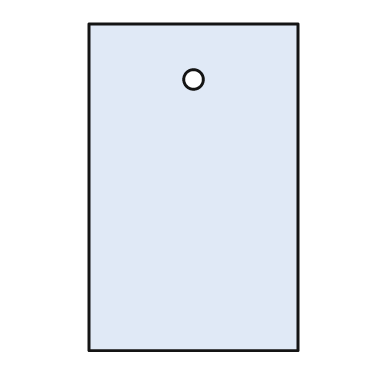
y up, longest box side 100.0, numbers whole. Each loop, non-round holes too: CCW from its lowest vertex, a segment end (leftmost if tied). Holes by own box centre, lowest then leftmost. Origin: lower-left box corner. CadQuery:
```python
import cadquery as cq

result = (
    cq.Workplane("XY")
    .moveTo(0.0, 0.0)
    .lineTo(64.0, 0.0)
    .lineTo(64.0, 100.0)
    .lineTo(0.0, 100.0)
    .close()
    .moveTo(32.0, 83.0)
    .circle(3.0)
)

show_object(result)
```